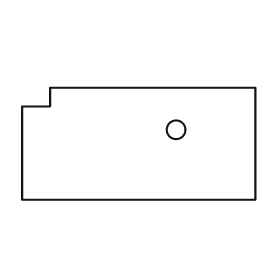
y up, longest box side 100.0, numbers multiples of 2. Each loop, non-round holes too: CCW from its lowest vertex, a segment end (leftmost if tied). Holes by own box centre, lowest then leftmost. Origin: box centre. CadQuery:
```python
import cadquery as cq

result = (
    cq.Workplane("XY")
    .moveTo(-50.0, -24.0)
    .lineTo(50.0, -24.0)
    .lineTo(50.0, 24.0)
    .lineTo(-38.0, 24.0)
    .lineTo(-38.0, 16.0)
    .lineTo(-50.0, 16.0)
    .close()
    .moveTo(16.0, 6.0)
    .circle(4.0)
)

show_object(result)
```